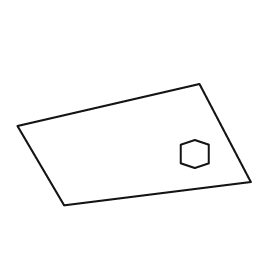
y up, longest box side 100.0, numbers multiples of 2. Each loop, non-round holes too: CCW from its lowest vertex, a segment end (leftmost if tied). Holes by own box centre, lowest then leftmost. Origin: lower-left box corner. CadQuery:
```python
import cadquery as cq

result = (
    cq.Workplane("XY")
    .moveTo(20.0, 0.0)
    .lineTo(100.0, 10.0)
    .lineTo(78.0, 52.0)
    .lineTo(0.0, 34.0)
    .close()
    .moveTo(76.0, 16.0)
    .lineTo(82.0, 18.0)
    .lineTo(82.0, 26.0)
    .lineTo(76.0, 28.0)
    .lineTo(70.0, 26.0)
    .lineTo(70.0, 18.0)
    .close()
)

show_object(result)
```